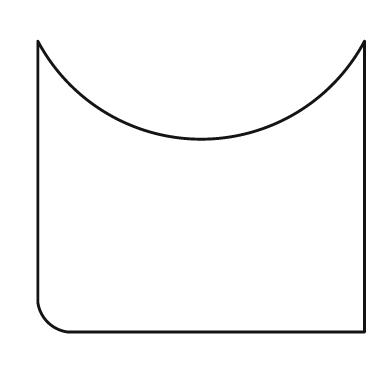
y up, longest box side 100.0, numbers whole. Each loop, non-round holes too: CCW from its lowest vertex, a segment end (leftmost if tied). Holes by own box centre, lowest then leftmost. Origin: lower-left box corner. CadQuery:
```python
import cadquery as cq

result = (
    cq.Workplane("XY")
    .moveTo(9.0, 0.0)
    .lineTo(100.0, 0.0)
    .lineTo(100.0, 89.0)
    .threePointArc((50.0, 59.0), (0.0, 89.0))
    .lineTo(0.0, 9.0)
    .threePointArc((3.0, 3.0), (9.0, 0.0))
    .close()
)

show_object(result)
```